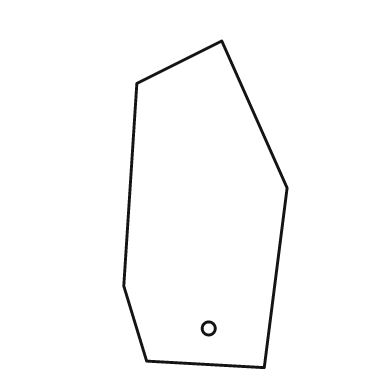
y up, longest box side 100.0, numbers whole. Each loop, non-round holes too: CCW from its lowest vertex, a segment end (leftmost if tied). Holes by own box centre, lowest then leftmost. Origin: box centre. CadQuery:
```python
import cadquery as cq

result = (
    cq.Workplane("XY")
    .moveTo(18.0, -50.0)
    .lineTo(25.0, 5.0)
    .lineTo(5.0, 50.0)
    .lineTo(-21.0, 37.0)
    .lineTo(-25.0, -25.0)
    .lineTo(-18.0, -48.0)
    .close()
    .moveTo(1.0, -38.0)
    .circle(2.0)
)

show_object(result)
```